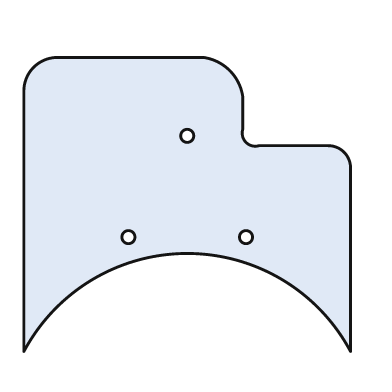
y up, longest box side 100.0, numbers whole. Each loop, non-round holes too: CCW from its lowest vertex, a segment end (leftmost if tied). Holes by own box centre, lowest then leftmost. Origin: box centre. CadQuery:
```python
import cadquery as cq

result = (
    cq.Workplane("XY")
    .moveTo(-50.0, -45.0)
    .threePointArc((0.0, -15.0), (50.0, -45.0))
    .lineTo(50.0, 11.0)
    .threePointArc((48.0, 16.0), (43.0, 18.0))
    .lineTo(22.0, 18.0)
    .threePointArc((18.0, 19.0), (17.0, 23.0))
    .lineTo(17.0, 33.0)
    .threePointArc((13.0, 41.0), (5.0, 45.0))
    .lineTo(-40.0, 45.0)
    .threePointArc((-47.0, 42.0), (-50.0, 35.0))
    .close()
    .moveTo(-18.0, -10.0)
    .circle(2.0)
    .moveTo(18.0, -10.0)
    .circle(2.0)
    .moveTo(0.0, 21.0)
    .circle(2.0)
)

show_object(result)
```